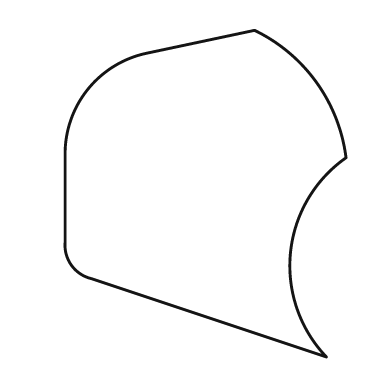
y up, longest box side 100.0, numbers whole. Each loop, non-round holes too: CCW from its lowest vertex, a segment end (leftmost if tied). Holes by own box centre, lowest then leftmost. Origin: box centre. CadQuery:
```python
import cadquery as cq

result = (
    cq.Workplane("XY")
    .moveTo(37.0, -50.0)
    .threePointArc((26.0, -18.0), (43.0, 11.0))
    .threePointArc((34.0, 34.0), (15.0, 50.0))
    .lineTo(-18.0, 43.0)
    .threePointArc((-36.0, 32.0), (-43.0, 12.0))
    .lineTo(-43.0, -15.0)
    .threePointArc((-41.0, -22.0), (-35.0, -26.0))
    .close()
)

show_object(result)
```